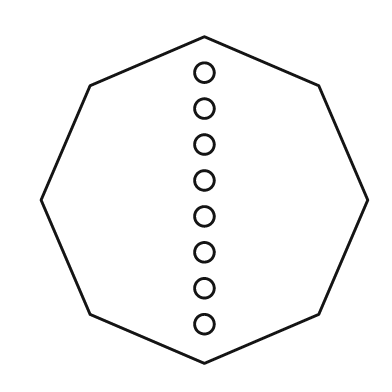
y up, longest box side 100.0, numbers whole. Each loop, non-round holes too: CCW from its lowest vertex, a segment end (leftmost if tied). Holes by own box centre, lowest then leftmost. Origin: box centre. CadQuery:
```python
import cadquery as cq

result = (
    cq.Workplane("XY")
    .moveTo(0.0, -50.0)
    .lineTo(35.0, -35.0)
    .lineTo(50.0, 0.0)
    .lineTo(35.0, 35.0)
    .lineTo(0.0, 50.0)
    .lineTo(-35.0, 35.0)
    .lineTo(-50.0, 0.0)
    .lineTo(-35.0, -35.0)
    .close()
    .moveTo(0.0, -38.0)
    .circle(3.0)
    .moveTo(0.0, -27.0)
    .circle(3.0)
    .moveTo(0.0, -16.0)
    .circle(3.0)
    .moveTo(0.0, -5.0)
    .circle(3.0)
    .moveTo(0.0, 6.0)
    .circle(3.0)
    .moveTo(0.0, 17.0)
    .circle(3.0)
    .moveTo(0.0, 28.0)
    .circle(3.0)
    .moveTo(0.0, 39.0)
    .circle(3.0)
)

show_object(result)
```